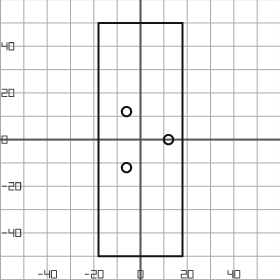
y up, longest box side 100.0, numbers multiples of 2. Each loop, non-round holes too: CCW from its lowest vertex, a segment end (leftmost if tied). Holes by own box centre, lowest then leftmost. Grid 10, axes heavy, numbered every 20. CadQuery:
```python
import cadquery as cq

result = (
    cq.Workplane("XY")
    .moveTo(-18.0, -50.0)
    .lineTo(18.0, -50.0)
    .lineTo(18.0, 50.0)
    .lineTo(-18.0, 50.0)
    .close()
    .moveTo(-6.0, -12.0)
    .circle(2.0)
    .moveTo(12.0, 0.0)
    .circle(2.0)
    .moveTo(-6.0, 12.0)
    .circle(2.0)
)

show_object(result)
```